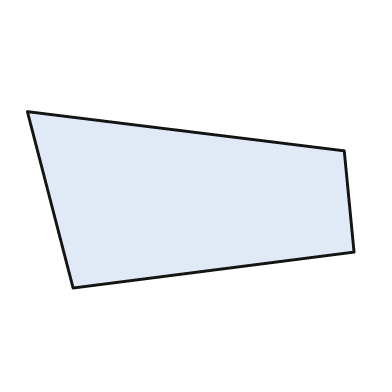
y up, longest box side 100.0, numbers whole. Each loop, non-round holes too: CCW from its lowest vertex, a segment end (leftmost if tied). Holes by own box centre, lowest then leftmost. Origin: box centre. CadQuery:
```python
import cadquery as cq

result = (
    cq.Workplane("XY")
    .moveTo(-36.0, -27.0)
    .lineTo(50.0, -16.0)
    .lineTo(47.0, 15.0)
    .lineTo(-50.0, 27.0)
    .close()
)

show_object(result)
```